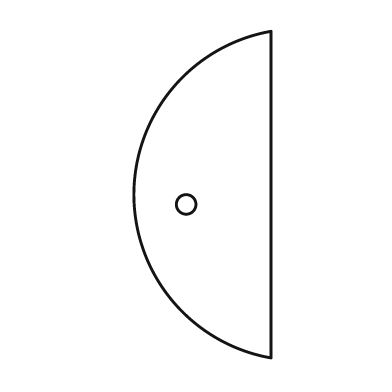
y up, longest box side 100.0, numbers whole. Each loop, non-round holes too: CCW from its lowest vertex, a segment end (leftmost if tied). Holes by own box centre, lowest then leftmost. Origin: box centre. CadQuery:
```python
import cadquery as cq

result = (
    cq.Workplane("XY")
    .moveTo(21.0, -50.0)
    .lineTo(21.0, 50.0)
    .threePointArc((-21.0, 0.0), (21.0, -50.0))
    .close()
    .moveTo(-5.0, -3.0)
    .circle(3.0)
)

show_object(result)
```